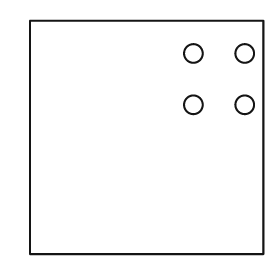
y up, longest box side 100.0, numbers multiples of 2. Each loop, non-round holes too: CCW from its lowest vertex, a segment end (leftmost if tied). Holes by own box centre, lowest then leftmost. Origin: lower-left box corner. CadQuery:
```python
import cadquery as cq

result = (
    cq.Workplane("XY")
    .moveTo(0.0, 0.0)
    .lineTo(100.0, 0.0)
    .lineTo(100.0, 100.0)
    .lineTo(0.0, 100.0)
    .close()
    .moveTo(70.0, 64.0)
    .circle(4.0)
    .moveTo(92.0, 64.0)
    .circle(4.0)
    .moveTo(70.0, 86.0)
    .circle(4.0)
    .moveTo(92.0, 86.0)
    .circle(4.0)
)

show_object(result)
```